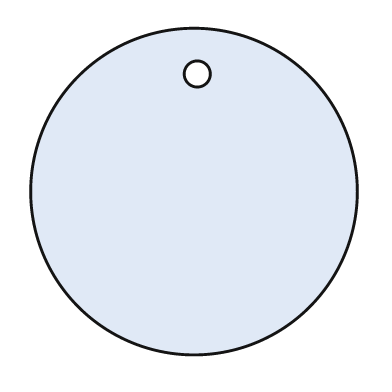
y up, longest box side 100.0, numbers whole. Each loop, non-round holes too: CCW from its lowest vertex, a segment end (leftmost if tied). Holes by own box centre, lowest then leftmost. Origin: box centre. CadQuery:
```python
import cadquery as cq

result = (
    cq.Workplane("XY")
    .moveTo(0.0, 0.0)
    .circle(50.0)
    .moveTo(1.0, 36.0)
    .circle(4.0)
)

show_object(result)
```